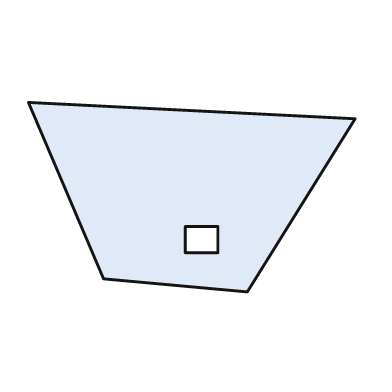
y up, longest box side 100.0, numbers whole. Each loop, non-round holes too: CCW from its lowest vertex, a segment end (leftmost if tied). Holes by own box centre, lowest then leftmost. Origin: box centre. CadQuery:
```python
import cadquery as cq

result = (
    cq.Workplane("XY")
    .moveTo(17.0, -29.0)
    .lineTo(50.0, 24.0)
    .lineTo(-50.0, 29.0)
    .lineTo(-27.0, -25.0)
    .close()
    .moveTo(-2.0, -17.0)
    .lineTo(8.0, -17.0)
    .lineTo(8.0, -9.0)
    .lineTo(-2.0, -9.0)
    .close()
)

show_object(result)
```